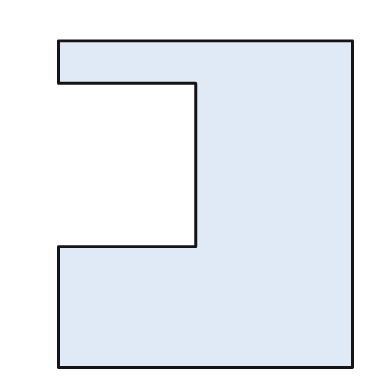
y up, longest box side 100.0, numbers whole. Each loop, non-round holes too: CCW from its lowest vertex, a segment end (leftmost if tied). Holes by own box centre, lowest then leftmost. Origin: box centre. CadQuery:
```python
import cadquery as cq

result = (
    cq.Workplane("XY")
    .moveTo(-45.0, -50.0)
    .lineTo(45.0, -50.0)
    .lineTo(45.0, 50.0)
    .lineTo(-45.0, 50.0)
    .lineTo(-45.0, 37.0)
    .lineTo(-3.0, 37.0)
    .lineTo(-3.0, -13.0)
    .lineTo(-45.0, -13.0)
    .close()
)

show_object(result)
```